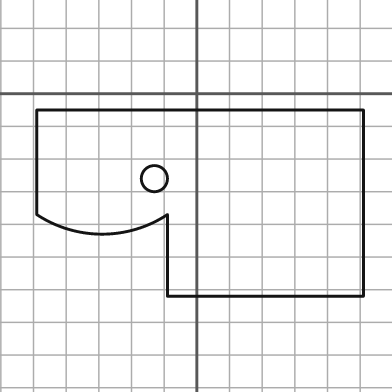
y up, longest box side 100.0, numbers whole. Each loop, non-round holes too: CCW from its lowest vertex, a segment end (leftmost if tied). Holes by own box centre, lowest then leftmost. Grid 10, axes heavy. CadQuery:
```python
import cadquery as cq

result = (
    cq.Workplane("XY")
    .moveTo(-9.0, -62.0)
    .lineTo(51.0, -62.0)
    .lineTo(51.0, -5.0)
    .lineTo(-49.0, -5.0)
    .lineTo(-49.0, -37.0)
    .threePointArc((-29.0, -43.0), (-9.0, -37.0))
    .close()
    .moveTo(-13.0, -26.0)
    .circle(4.0)
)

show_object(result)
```